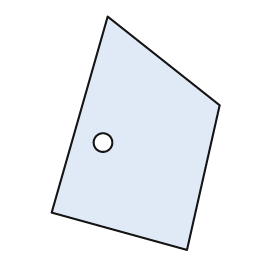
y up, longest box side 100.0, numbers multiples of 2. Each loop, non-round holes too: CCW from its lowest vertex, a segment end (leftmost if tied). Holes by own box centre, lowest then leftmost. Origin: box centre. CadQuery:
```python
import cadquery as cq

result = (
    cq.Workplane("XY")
    .moveTo(22.0, -50.0)
    .lineTo(36.0, 12.0)
    .lineTo(-12.0, 50.0)
    .lineTo(-36.0, -34.0)
    .close()
    .moveTo(-14.0, -4.0)
    .circle(4.0)
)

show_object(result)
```